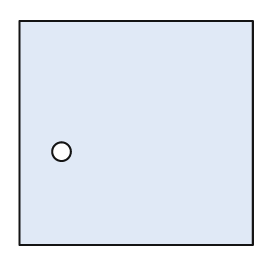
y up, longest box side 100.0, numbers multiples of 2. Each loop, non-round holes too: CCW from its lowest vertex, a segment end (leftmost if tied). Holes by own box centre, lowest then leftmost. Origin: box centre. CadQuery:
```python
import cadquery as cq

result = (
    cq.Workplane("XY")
    .moveTo(-50.0, -48.0)
    .lineTo(50.0, -48.0)
    .lineTo(50.0, 48.0)
    .lineTo(-50.0, 48.0)
    .close()
    .moveTo(-32.0, -8.0)
    .circle(4.0)
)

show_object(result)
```